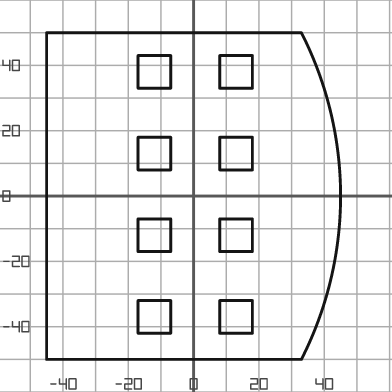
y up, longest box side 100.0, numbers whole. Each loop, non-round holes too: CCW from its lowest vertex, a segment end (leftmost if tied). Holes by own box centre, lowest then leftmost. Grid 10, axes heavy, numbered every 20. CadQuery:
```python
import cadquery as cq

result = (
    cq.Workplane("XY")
    .moveTo(-45.0, -50.0)
    .lineTo(33.0, -50.0)
    .threePointArc((45.0, 0.0), (33.0, 50.0))
    .lineTo(-45.0, 50.0)
    .close()
    .moveTo(-17.0, -42.0)
    .lineTo(-7.0, -42.0)
    .lineTo(-7.0, -32.0)
    .lineTo(-17.0, -32.0)
    .close()
    .moveTo(8.0, -42.0)
    .lineTo(18.0, -42.0)
    .lineTo(18.0, -32.0)
    .lineTo(8.0, -32.0)
    .close()
    .moveTo(-17.0, -17.0)
    .lineTo(-7.0, -17.0)
    .lineTo(-7.0, -7.0)
    .lineTo(-17.0, -7.0)
    .close()
    .moveTo(8.0, -17.0)
    .lineTo(18.0, -17.0)
    .lineTo(18.0, -7.0)
    .lineTo(8.0, -7.0)
    .close()
    .moveTo(-17.0, 8.0)
    .lineTo(-7.0, 8.0)
    .lineTo(-7.0, 18.0)
    .lineTo(-17.0, 18.0)
    .close()
    .moveTo(8.0, 8.0)
    .lineTo(18.0, 8.0)
    .lineTo(18.0, 18.0)
    .lineTo(8.0, 18.0)
    .close()
    .moveTo(-17.0, 33.0)
    .lineTo(-7.0, 33.0)
    .lineTo(-7.0, 43.0)
    .lineTo(-17.0, 43.0)
    .close()
    .moveTo(8.0, 33.0)
    .lineTo(18.0, 33.0)
    .lineTo(18.0, 43.0)
    .lineTo(8.0, 43.0)
    .close()
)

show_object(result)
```